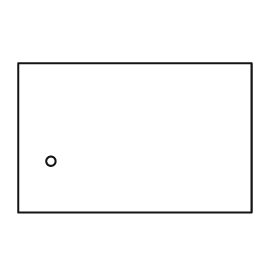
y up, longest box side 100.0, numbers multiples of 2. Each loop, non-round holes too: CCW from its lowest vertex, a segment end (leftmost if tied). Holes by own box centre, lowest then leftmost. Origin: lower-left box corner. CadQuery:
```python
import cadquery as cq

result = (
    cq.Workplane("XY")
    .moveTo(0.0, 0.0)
    .lineTo(100.0, 0.0)
    .lineTo(100.0, 64.0)
    .lineTo(0.0, 64.0)
    .close()
    .moveTo(14.0, 22.0)
    .circle(2.0)
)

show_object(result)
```